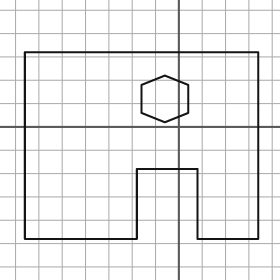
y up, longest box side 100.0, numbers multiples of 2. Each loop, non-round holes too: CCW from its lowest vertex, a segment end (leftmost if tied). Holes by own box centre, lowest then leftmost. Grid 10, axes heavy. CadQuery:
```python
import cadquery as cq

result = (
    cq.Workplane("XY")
    .moveTo(-66.0, -48.0)
    .lineTo(-18.0, -48.0)
    .lineTo(-18.0, -18.0)
    .lineTo(8.0, -18.0)
    .lineTo(8.0, -48.0)
    .lineTo(34.0, -48.0)
    .lineTo(34.0, 32.0)
    .lineTo(-66.0, 32.0)
    .close()
    .moveTo(-6.0, 2.0)
    .lineTo(4.0, 6.0)
    .lineTo(4.0, 18.0)
    .lineTo(-6.0, 22.0)
    .lineTo(-16.0, 18.0)
    .lineTo(-16.0, 6.0)
    .close()
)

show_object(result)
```